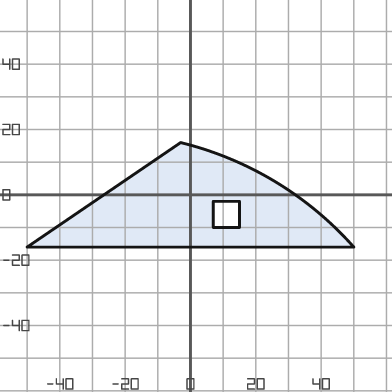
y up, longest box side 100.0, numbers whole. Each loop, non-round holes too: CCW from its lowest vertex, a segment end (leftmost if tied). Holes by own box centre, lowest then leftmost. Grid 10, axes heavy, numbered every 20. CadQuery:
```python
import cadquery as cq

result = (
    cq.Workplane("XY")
    .moveTo(-50.0, -16.0)
    .lineTo(50.0, -16.0)
    .threePointArc((26.0, 4.0), (-3.0, 16.0))
    .close()
    .moveTo(7.0, -10.0)
    .lineTo(15.0, -10.0)
    .lineTo(15.0, -2.0)
    .lineTo(7.0, -2.0)
    .close()
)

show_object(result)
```